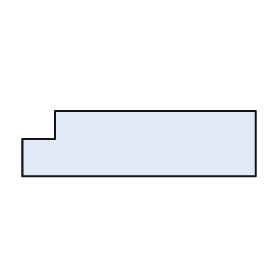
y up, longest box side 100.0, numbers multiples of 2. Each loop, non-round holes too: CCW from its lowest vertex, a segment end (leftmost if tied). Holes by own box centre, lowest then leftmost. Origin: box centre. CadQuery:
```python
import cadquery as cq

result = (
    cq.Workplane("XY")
    .moveTo(-50.0, -14.0)
    .lineTo(50.0, -14.0)
    .lineTo(50.0, 14.0)
    .lineTo(-36.0, 14.0)
    .lineTo(-36.0, 2.0)
    .lineTo(-50.0, 2.0)
    .close()
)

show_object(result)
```